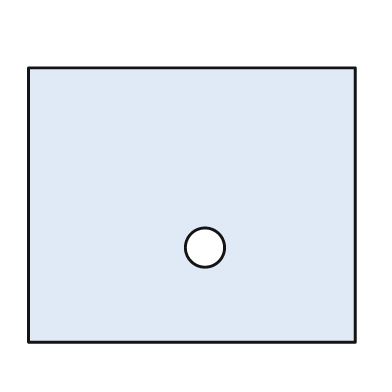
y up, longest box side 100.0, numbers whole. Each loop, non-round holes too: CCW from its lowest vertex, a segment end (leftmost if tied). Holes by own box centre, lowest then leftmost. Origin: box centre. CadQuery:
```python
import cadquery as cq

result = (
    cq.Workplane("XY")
    .moveTo(-50.0, -42.0)
    .lineTo(50.0, -42.0)
    .lineTo(50.0, 42.0)
    .lineTo(-50.0, 42.0)
    .close()
    .moveTo(4.0, -13.0)
    .circle(6.0)
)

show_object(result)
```